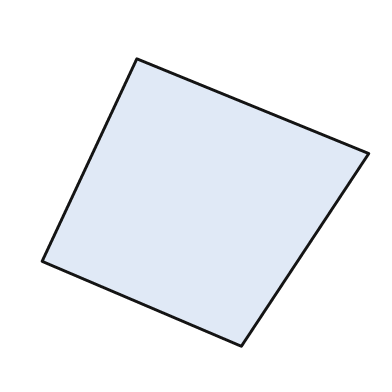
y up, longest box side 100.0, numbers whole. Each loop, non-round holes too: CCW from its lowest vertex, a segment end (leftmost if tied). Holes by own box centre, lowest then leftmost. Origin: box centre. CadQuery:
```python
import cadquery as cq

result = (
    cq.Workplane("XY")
    .moveTo(11.0, -44.0)
    .lineTo(50.0, 15.0)
    .lineTo(-21.0, 44.0)
    .lineTo(-50.0, -18.0)
    .close()
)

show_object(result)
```